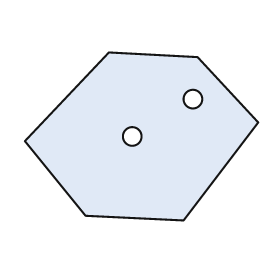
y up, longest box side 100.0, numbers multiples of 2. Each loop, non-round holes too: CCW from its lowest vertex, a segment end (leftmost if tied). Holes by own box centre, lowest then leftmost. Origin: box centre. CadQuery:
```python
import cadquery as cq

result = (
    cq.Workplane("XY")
    .moveTo(18.0, -36.0)
    .lineTo(50.0, 6.0)
    .lineTo(24.0, 34.0)
    .lineTo(-14.0, 36.0)
    .lineTo(-50.0, -2.0)
    .lineTo(-24.0, -34.0)
    .close()
    .moveTo(-4.0, 0.0)
    .circle(4.0)
    .moveTo(22.0, 16.0)
    .circle(4.0)
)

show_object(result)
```